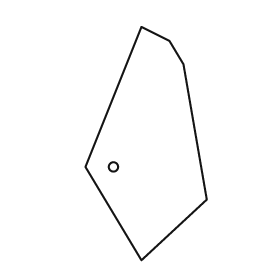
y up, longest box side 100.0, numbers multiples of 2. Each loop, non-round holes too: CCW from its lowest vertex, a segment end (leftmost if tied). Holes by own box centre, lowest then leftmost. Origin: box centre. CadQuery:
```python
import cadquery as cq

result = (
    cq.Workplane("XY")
    .moveTo(-2.0, -50.0)
    .lineTo(26.0, -24.0)
    .lineTo(16.0, 34.0)
    .lineTo(10.0, 44.0)
    .lineTo(-2.0, 50.0)
    .lineTo(-26.0, -10.0)
    .close()
    .moveTo(-14.0, -10.0)
    .circle(2.0)
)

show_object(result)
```